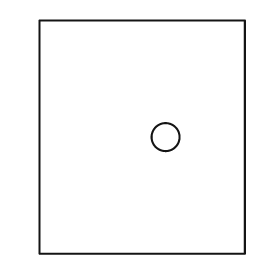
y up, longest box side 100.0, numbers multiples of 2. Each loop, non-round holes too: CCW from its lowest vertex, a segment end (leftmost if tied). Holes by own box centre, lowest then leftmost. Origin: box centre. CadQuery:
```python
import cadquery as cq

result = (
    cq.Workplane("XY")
    .moveTo(-44.0, -50.0)
    .lineTo(44.0, -50.0)
    .lineTo(44.0, 50.0)
    .lineTo(-44.0, 50.0)
    .close()
    .moveTo(10.0, 0.0)
    .circle(6.0)
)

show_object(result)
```